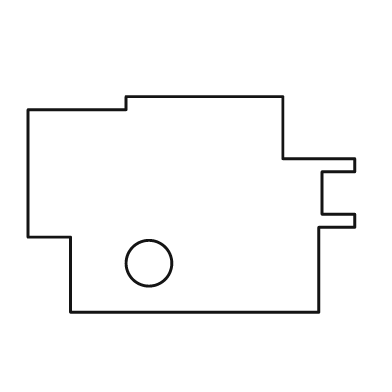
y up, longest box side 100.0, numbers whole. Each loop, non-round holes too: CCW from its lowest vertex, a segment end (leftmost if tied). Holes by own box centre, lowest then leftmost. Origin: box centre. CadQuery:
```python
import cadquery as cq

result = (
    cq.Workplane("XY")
    .moveTo(-37.0, -33.0)
    .lineTo(39.0, -33.0)
    .lineTo(39.0, -7.0)
    .lineTo(50.0, -7.0)
    .lineTo(50.0, -3.0)
    .lineTo(40.0, -3.0)
    .lineTo(40.0, 10.0)
    .lineTo(50.0, 10.0)
    .lineTo(50.0, 14.0)
    .lineTo(28.0, 14.0)
    .lineTo(28.0, 33.0)
    .lineTo(-20.0, 33.0)
    .lineTo(-20.0, 29.0)
    .lineTo(-50.0, 29.0)
    .lineTo(-50.0, -10.0)
    .lineTo(-37.0, -10.0)
    .close()
    .moveTo(-13.0, -18.0)
    .circle(7.0)
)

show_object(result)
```